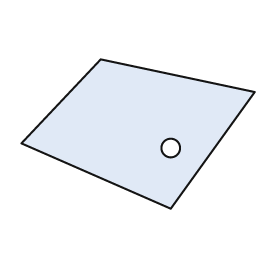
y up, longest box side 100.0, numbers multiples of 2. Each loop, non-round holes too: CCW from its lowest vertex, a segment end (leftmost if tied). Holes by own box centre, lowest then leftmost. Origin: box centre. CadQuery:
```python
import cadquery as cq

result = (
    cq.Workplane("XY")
    .moveTo(14.0, -32.0)
    .lineTo(50.0, 18.0)
    .lineTo(-16.0, 32.0)
    .lineTo(-50.0, -4.0)
    .close()
    .moveTo(14.0, -6.0)
    .circle(4.0)
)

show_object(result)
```